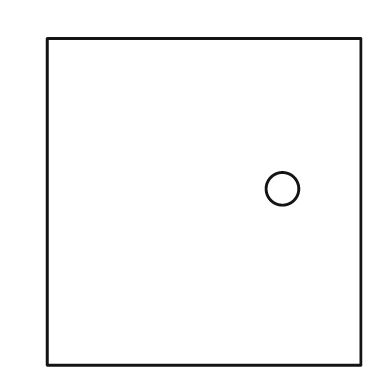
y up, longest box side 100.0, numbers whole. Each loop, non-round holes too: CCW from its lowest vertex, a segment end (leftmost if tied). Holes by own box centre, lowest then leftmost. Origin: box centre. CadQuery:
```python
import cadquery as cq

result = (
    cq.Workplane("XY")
    .moveTo(-48.0, -50.0)
    .lineTo(48.0, -50.0)
    .lineTo(48.0, 50.0)
    .lineTo(-48.0, 50.0)
    .close()
    .moveTo(24.0, 4.0)
    .circle(5.0)
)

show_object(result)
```